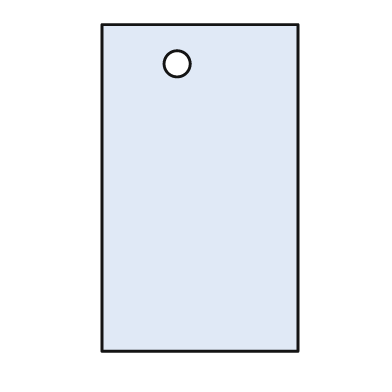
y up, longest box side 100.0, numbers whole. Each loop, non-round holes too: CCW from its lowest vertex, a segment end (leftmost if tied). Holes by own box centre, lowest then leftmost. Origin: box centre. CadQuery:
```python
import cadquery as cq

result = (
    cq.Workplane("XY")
    .moveTo(-30.0, -50.0)
    .lineTo(30.0, -50.0)
    .lineTo(30.0, 50.0)
    .lineTo(-30.0, 50.0)
    .close()
    .moveTo(-7.0, 38.0)
    .circle(4.0)
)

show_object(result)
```